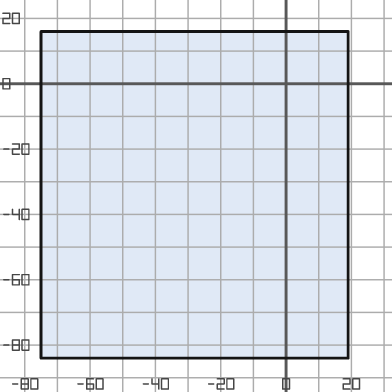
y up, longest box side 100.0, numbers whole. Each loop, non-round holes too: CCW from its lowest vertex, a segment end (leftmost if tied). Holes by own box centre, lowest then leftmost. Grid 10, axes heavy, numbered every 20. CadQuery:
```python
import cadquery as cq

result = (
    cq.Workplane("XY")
    .moveTo(-75.0, -84.0)
    .lineTo(19.0, -84.0)
    .lineTo(19.0, 16.0)
    .lineTo(-75.0, 16.0)
    .close()
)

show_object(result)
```